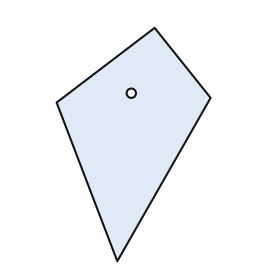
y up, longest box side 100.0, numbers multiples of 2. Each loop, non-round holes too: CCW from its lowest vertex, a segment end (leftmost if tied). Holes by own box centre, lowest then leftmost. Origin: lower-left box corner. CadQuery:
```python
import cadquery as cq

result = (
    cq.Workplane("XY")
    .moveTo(26.0, 0.0)
    .lineTo(66.0, 70.0)
    .lineTo(42.0, 100.0)
    .lineTo(0.0, 68.0)
    .close()
    .moveTo(32.0, 72.0)
    .circle(2.0)
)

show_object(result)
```